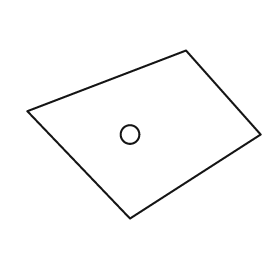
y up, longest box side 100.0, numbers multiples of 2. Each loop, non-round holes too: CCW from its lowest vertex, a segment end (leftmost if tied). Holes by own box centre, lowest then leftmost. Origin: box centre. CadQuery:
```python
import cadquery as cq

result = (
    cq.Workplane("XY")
    .moveTo(-6.0, -36.0)
    .lineTo(50.0, 0.0)
    .lineTo(18.0, 36.0)
    .lineTo(-50.0, 10.0)
    .close()
    .moveTo(-6.0, 0.0)
    .circle(4.0)
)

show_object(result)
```